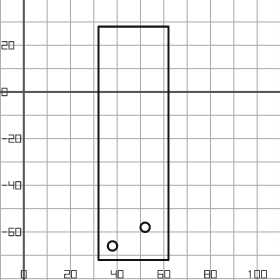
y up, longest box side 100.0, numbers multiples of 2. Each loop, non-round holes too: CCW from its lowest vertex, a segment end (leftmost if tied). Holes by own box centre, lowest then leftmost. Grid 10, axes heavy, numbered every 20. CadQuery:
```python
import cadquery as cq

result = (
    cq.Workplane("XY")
    .moveTo(32.0, -72.0)
    .lineTo(62.0, -72.0)
    .lineTo(62.0, 28.0)
    .lineTo(32.0, 28.0)
    .close()
    .moveTo(38.0, -66.0)
    .circle(2.0)
    .moveTo(52.0, -58.0)
    .circle(2.0)
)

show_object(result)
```